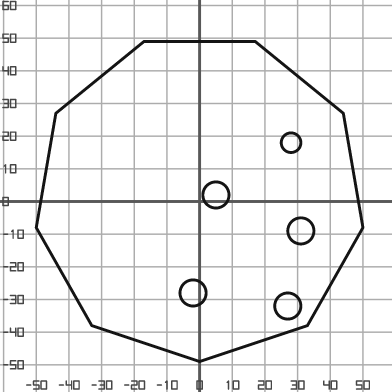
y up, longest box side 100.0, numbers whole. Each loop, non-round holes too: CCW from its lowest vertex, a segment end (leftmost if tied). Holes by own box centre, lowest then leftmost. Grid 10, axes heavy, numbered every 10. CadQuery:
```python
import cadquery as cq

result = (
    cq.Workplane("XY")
    .moveTo(0.0, -49.0)
    .lineTo(33.0, -38.0)
    .lineTo(50.0, -8.0)
    .lineTo(44.0, 27.0)
    .lineTo(17.0, 49.0)
    .lineTo(-17.0, 49.0)
    .lineTo(-44.0, 27.0)
    .lineTo(-50.0, -8.0)
    .lineTo(-33.0, -38.0)
    .close()
    .moveTo(27.0, -32.0)
    .circle(4.0)
    .moveTo(-2.0, -28.0)
    .circle(4.0)
    .moveTo(31.0, -9.0)
    .circle(4.0)
    .moveTo(5.0, 2.0)
    .circle(4.0)
    .moveTo(28.0, 18.0)
    .circle(3.0)
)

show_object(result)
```